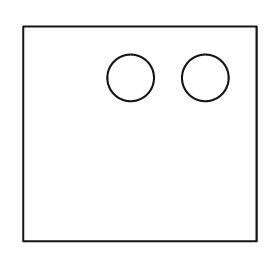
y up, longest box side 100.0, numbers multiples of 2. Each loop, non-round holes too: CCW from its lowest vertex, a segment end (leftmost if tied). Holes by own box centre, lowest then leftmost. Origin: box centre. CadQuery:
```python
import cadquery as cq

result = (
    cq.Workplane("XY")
    .moveTo(-50.0, -46.0)
    .lineTo(50.0, -46.0)
    .lineTo(50.0, 46.0)
    .lineTo(-50.0, 46.0)
    .close()
    .moveTo(-4.0, 24.0)
    .circle(10.0)
    .moveTo(28.0, 24.0)
    .circle(10.0)
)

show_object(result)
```